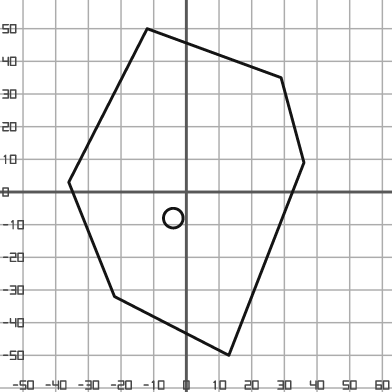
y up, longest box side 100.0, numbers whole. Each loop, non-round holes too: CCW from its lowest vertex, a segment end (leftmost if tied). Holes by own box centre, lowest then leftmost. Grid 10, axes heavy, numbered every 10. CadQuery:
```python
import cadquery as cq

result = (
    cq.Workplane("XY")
    .moveTo(13.0, -50.0)
    .lineTo(36.0, 9.0)
    .lineTo(29.0, 35.0)
    .lineTo(-12.0, 50.0)
    .lineTo(-36.0, 3.0)
    .lineTo(-22.0, -32.0)
    .close()
    .moveTo(-4.0, -8.0)
    .circle(3.0)
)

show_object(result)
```